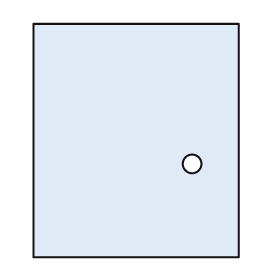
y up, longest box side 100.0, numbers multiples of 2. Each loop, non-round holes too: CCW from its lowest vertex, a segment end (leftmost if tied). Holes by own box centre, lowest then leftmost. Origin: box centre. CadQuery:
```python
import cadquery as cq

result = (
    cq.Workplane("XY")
    .moveTo(-44.0, -50.0)
    .lineTo(44.0, -50.0)
    .lineTo(44.0, 50.0)
    .lineTo(-44.0, 50.0)
    .close()
    .moveTo(24.0, -10.0)
    .circle(4.0)
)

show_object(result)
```